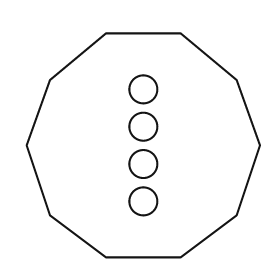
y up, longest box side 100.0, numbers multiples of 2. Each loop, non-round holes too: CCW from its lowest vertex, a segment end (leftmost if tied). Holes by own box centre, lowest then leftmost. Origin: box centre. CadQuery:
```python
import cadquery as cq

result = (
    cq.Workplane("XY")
    .moveTo(-16.0, -48.0)
    .lineTo(16.0, -48.0)
    .lineTo(40.0, -30.0)
    .lineTo(50.0, 0.0)
    .lineTo(40.0, 28.0)
    .lineTo(16.0, 48.0)
    .lineTo(-16.0, 48.0)
    .lineTo(-40.0, 28.0)
    .lineTo(-50.0, 0.0)
    .lineTo(-40.0, -30.0)
    .close()
    .moveTo(0.0, -24.0)
    .circle(6.0)
    .moveTo(0.0, -8.0)
    .circle(6.0)
    .moveTo(0.0, 8.0)
    .circle(6.0)
    .moveTo(0.0, 24.0)
    .circle(6.0)
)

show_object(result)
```